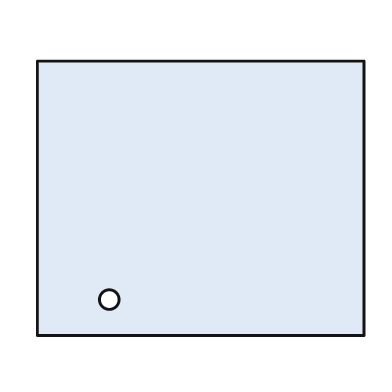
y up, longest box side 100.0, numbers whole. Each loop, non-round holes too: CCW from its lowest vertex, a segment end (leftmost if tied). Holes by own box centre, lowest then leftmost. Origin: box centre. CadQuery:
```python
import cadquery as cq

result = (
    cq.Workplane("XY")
    .moveTo(-50.0, -42.0)
    .lineTo(50.0, -42.0)
    .lineTo(50.0, 42.0)
    .lineTo(-50.0, 42.0)
    .close()
    .moveTo(-28.0, -31.0)
    .circle(3.0)
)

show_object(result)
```